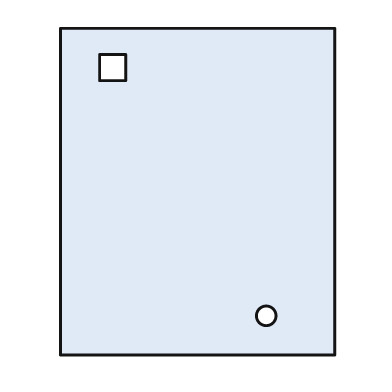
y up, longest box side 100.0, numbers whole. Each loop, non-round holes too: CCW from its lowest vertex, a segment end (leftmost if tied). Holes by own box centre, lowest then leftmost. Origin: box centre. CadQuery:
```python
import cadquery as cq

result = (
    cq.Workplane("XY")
    .moveTo(-42.0, -50.0)
    .lineTo(42.0, -50.0)
    .lineTo(42.0, 50.0)
    .lineTo(-42.0, 50.0)
    .close()
    .moveTo(21.0, -38.0)
    .circle(3.0)
    .moveTo(-30.0, 34.0)
    .lineTo(-22.0, 34.0)
    .lineTo(-22.0, 42.0)
    .lineTo(-30.0, 42.0)
    .close()
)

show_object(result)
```